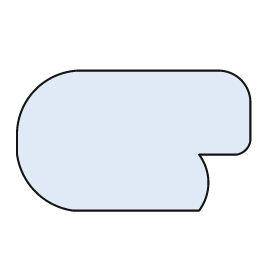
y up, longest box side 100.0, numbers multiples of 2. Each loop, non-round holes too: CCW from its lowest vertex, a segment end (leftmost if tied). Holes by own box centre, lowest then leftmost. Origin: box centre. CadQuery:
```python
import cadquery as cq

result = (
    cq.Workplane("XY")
    .moveTo(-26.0, -30.0)
    .lineTo(28.0, -30.0)
    .threePointArc((32.0, -18.0), (28.0, -6.0))
    .lineTo(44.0, -6.0)
    .threePointArc((48.0, -4.0), (50.0, 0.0))
    .lineTo(50.0, 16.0)
    .threePointArc((46.0, 26.0), (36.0, 30.0))
    .lineTo(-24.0, 30.0)
    .threePointArc((-42.0, 22.0), (-50.0, 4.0))
    .lineTo(-50.0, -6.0)
    .threePointArc((-42.0, -22.0), (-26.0, -30.0))
    .close()
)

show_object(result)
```